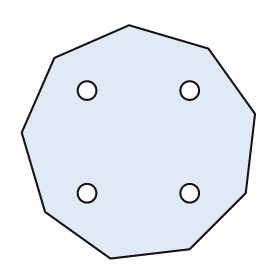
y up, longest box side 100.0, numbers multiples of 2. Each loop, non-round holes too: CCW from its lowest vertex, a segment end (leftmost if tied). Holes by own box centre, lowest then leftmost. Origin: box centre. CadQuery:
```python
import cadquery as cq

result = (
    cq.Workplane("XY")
    .moveTo(-12.0, -50.0)
    .lineTo(22.0, -46.0)
    .lineTo(46.0, -22.0)
    .lineTo(50.0, 12.0)
    .lineTo(30.0, 40.0)
    .lineTo(-4.0, 50.0)
    .lineTo(-36.0, 36.0)
    .lineTo(-50.0, 4.0)
    .lineTo(-40.0, -30.0)
    .close()
    .moveTo(-22.0, -22.0)
    .circle(4.0)
    .moveTo(22.0, -22.0)
    .circle(4.0)
    .moveTo(-22.0, 22.0)
    .circle(4.0)
    .moveTo(22.0, 22.0)
    .circle(4.0)
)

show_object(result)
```